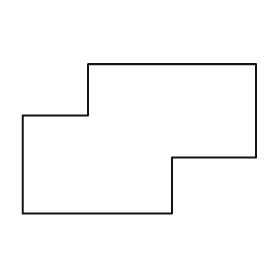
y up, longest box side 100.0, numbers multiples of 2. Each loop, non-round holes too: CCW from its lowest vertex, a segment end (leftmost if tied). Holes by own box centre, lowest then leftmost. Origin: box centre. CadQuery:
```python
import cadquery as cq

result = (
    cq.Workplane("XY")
    .moveTo(-50.0, -32.0)
    .lineTo(14.0, -32.0)
    .lineTo(14.0, -8.0)
    .lineTo(50.0, -8.0)
    .lineTo(50.0, 32.0)
    .lineTo(-22.0, 32.0)
    .lineTo(-22.0, 10.0)
    .lineTo(-50.0, 10.0)
    .close()
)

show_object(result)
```